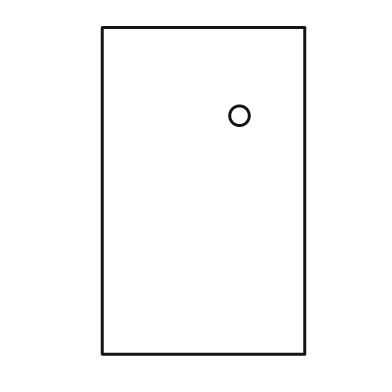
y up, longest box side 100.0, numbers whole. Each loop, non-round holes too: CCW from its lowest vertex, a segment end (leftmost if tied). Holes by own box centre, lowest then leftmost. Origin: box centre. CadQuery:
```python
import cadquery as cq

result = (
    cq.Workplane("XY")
    .moveTo(-31.0, -50.0)
    .lineTo(31.0, -50.0)
    .lineTo(31.0, 50.0)
    .lineTo(-31.0, 50.0)
    .close()
    .moveTo(11.0, 23.0)
    .circle(3.0)
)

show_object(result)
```